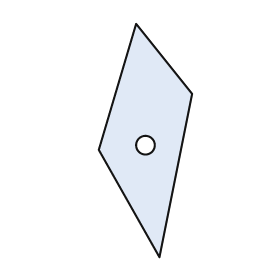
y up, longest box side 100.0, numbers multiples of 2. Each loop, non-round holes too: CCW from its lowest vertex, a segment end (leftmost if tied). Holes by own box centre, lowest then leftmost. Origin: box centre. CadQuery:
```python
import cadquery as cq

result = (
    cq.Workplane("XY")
    .moveTo(6.0, -50.0)
    .lineTo(20.0, 20.0)
    .lineTo(-4.0, 50.0)
    .lineTo(-20.0, -4.0)
    .close()
    .moveTo(0.0, -2.0)
    .circle(4.0)
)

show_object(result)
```